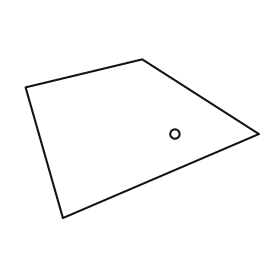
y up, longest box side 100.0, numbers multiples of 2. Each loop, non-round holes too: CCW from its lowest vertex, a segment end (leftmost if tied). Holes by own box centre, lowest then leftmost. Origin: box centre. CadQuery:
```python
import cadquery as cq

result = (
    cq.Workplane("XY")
    .moveTo(-34.0, -34.0)
    .lineTo(50.0, 2.0)
    .lineTo(0.0, 34.0)
    .lineTo(-50.0, 22.0)
    .close()
    .moveTo(14.0, 2.0)
    .circle(2.0)
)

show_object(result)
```